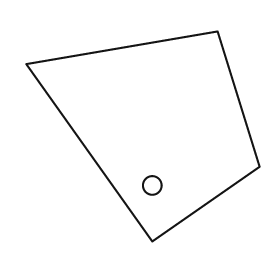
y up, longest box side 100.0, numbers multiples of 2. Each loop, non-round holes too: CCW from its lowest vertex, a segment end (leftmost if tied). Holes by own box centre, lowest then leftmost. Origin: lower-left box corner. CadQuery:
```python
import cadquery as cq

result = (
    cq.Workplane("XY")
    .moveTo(54.0, 0.0)
    .lineTo(100.0, 32.0)
    .lineTo(82.0, 90.0)
    .lineTo(0.0, 76.0)
    .close()
    .moveTo(54.0, 24.0)
    .circle(4.0)
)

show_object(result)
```